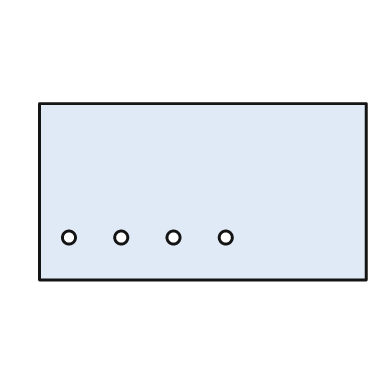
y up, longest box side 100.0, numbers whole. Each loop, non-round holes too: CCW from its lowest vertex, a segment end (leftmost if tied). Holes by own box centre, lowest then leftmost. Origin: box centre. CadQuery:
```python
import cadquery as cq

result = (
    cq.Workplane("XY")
    .moveTo(-50.0, -27.0)
    .lineTo(50.0, -27.0)
    .lineTo(50.0, 27.0)
    .lineTo(-50.0, 27.0)
    .close()
    .moveTo(-41.0, -14.0)
    .circle(2.0)
    .moveTo(-25.0, -14.0)
    .circle(2.0)
    .moveTo(-9.0, -14.0)
    .circle(2.0)
    .moveTo(7.0, -14.0)
    .circle(2.0)
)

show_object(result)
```